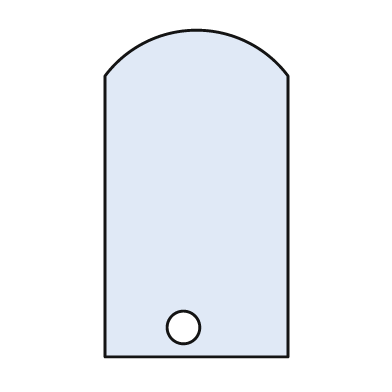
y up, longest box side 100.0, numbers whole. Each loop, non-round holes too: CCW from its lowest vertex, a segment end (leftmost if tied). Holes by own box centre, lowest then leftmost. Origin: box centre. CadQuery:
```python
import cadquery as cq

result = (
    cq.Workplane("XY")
    .moveTo(-28.0, -50.0)
    .lineTo(28.0, -50.0)
    .lineTo(28.0, 36.0)
    .threePointArc((0.0, 50.0), (-28.0, 36.0))
    .close()
    .moveTo(-4.0, -41.0)
    .circle(5.0)
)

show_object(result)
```